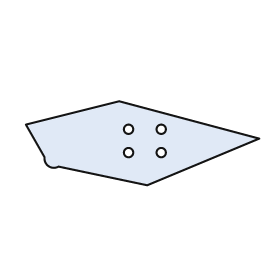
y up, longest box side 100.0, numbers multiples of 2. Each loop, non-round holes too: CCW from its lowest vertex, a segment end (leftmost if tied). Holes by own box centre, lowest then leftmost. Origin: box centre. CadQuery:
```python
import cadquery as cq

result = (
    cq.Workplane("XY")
    .moveTo(2.0, -18.0)
    .lineTo(50.0, 2.0)
    .lineTo(-10.0, 18.0)
    .lineTo(-50.0, 8.0)
    .lineTo(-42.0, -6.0)
    .threePointArc((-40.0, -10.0), (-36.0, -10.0))
    .close()
    .moveTo(-6.0, -4.0)
    .circle(2.0)
    .moveTo(8.0, -4.0)
    .circle(2.0)
    .moveTo(-6.0, 6.0)
    .circle(2.0)
    .moveTo(8.0, 6.0)
    .circle(2.0)
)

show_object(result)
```